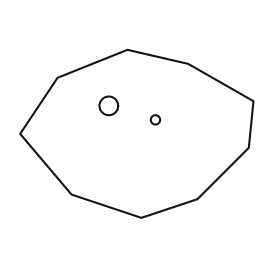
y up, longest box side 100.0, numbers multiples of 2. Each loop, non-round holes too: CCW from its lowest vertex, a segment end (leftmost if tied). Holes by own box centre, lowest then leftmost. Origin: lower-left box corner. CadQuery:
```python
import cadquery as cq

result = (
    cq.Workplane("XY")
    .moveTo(52.0, 0.0)
    .lineTo(76.0, 8.0)
    .lineTo(98.0, 30.0)
    .lineTo(100.0, 50.0)
    .lineTo(72.0, 66.0)
    .lineTo(46.0, 72.0)
    .lineTo(16.0, 60.0)
    .lineTo(0.0, 36.0)
    .lineTo(22.0, 10.0)
    .close()
    .moveTo(58.0, 42.0)
    .circle(2.0)
    .moveTo(38.0, 48.0)
    .circle(4.0)
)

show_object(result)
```